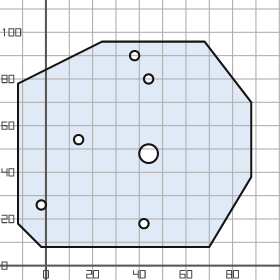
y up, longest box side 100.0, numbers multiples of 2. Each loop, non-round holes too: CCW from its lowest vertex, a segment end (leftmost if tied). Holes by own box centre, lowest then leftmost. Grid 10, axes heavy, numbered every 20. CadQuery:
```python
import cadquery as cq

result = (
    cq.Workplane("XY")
    .moveTo(-2.0, 8.0)
    .lineTo(70.0, 8.0)
    .lineTo(88.0, 38.0)
    .lineTo(88.0, 70.0)
    .lineTo(68.0, 96.0)
    .lineTo(24.0, 96.0)
    .lineTo(-12.0, 78.0)
    .lineTo(-12.0, 18.0)
    .close()
    .moveTo(42.0, 18.0)
    .circle(2.0)
    .moveTo(-2.0, 26.0)
    .circle(2.0)
    .moveTo(44.0, 48.0)
    .circle(4.0)
    .moveTo(14.0, 54.0)
    .circle(2.0)
    .moveTo(44.0, 80.0)
    .circle(2.0)
    .moveTo(38.0, 90.0)
    .circle(2.0)
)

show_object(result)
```